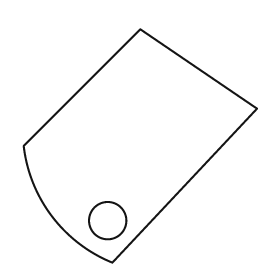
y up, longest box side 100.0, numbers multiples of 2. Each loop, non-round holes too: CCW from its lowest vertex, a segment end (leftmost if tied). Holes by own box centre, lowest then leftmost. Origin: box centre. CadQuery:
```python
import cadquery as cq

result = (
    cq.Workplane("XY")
    .moveTo(-12.0, -50.0)
    .lineTo(50.0, 16.0)
    .lineTo(0.0, 50.0)
    .lineTo(-50.0, 0.0)
    .threePointArc((-38.0, -30.0), (-12.0, -50.0))
    .close()
    .moveTo(-14.0, -32.0)
    .circle(8.0)
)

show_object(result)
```